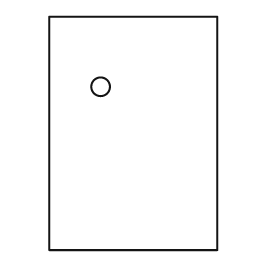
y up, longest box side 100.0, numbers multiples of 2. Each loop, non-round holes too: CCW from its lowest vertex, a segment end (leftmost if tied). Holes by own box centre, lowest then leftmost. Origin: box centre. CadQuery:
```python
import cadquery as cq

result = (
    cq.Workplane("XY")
    .moveTo(-36.0, -50.0)
    .lineTo(36.0, -50.0)
    .lineTo(36.0, 50.0)
    .lineTo(-36.0, 50.0)
    .close()
    .moveTo(-14.0, 20.0)
    .circle(4.0)
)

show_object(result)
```